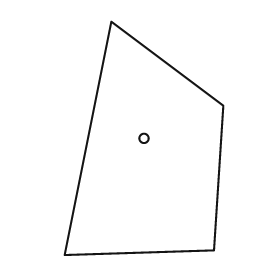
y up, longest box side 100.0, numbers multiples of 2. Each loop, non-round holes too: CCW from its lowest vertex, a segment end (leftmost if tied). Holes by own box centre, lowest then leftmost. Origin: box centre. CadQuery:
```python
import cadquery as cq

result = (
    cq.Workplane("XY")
    .moveTo(-34.0, -50.0)
    .lineTo(30.0, -48.0)
    .lineTo(34.0, 14.0)
    .lineTo(-14.0, 50.0)
    .close()
    .moveTo(0.0, 0.0)
    .circle(2.0)
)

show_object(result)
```